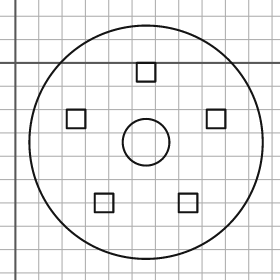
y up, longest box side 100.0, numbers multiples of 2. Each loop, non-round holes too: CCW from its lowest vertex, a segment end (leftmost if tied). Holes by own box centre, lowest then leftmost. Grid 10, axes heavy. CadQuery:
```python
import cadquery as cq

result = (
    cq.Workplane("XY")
    .moveTo(56.0, -34.0)
    .circle(50.0)
    .moveTo(34.0, -64.0)
    .lineTo(42.0, -64.0)
    .lineTo(42.0, -56.0)
    .lineTo(34.0, -56.0)
    .close()
    .moveTo(70.0, -64.0)
    .lineTo(78.0, -64.0)
    .lineTo(78.0, -56.0)
    .lineTo(70.0, -56.0)
    .close()
    .moveTo(56.0, -34.0)
    .circle(10.0)
    .moveTo(22.0, -28.0)
    .lineTo(30.0, -28.0)
    .lineTo(30.0, -20.0)
    .lineTo(22.0, -20.0)
    .close()
    .moveTo(82.0, -28.0)
    .lineTo(90.0, -28.0)
    .lineTo(90.0, -20.0)
    .lineTo(82.0, -20.0)
    .close()
    .moveTo(52.0, -8.0)
    .lineTo(60.0, -8.0)
    .lineTo(60.0, 0.0)
    .lineTo(52.0, 0.0)
    .close()
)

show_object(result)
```